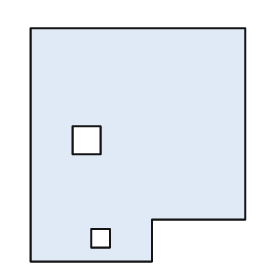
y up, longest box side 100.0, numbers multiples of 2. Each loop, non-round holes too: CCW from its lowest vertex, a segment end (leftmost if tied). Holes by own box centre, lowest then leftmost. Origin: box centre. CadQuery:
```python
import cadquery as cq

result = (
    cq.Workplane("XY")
    .moveTo(-46.0, -50.0)
    .lineTo(6.0, -50.0)
    .lineTo(6.0, -32.0)
    .lineTo(46.0, -32.0)
    .lineTo(46.0, 50.0)
    .lineTo(-46.0, 50.0)
    .close()
    .moveTo(-20.0, -44.0)
    .lineTo(-12.0, -44.0)
    .lineTo(-12.0, -36.0)
    .lineTo(-20.0, -36.0)
    .close()
    .moveTo(-28.0, -4.0)
    .lineTo(-16.0, -4.0)
    .lineTo(-16.0, 8.0)
    .lineTo(-28.0, 8.0)
    .close()
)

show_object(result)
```